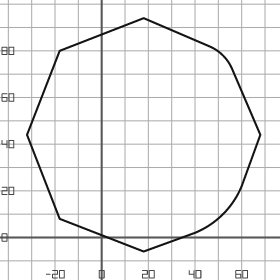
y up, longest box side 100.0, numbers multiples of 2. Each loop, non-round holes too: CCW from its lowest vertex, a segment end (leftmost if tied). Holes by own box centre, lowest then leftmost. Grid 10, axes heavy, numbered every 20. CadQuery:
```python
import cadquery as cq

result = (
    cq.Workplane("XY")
    .moveTo(18.0, -6.0)
    .lineTo(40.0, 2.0)
    .threePointArc((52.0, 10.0), (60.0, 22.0))
    .lineTo(68.0, 44.0)
    .lineTo(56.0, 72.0)
    .threePointArc((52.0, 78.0), (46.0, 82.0))
    .lineTo(18.0, 94.0)
    .lineTo(-18.0, 80.0)
    .lineTo(-32.0, 44.0)
    .lineTo(-18.0, 8.0)
    .close()
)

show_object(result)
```